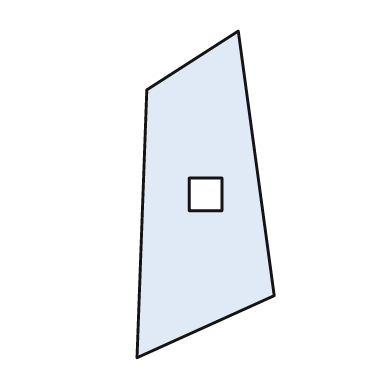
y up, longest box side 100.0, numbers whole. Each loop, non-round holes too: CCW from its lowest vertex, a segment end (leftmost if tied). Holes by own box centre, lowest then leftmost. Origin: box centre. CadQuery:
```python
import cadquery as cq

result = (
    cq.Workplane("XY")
    .moveTo(-21.0, -50.0)
    .lineTo(21.0, -31.0)
    .lineTo(10.0, 50.0)
    .lineTo(-18.0, 32.0)
    .close()
    .moveTo(-5.0, -5.0)
    .lineTo(5.0, -5.0)
    .lineTo(5.0, 5.0)
    .lineTo(-5.0, 5.0)
    .close()
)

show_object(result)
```